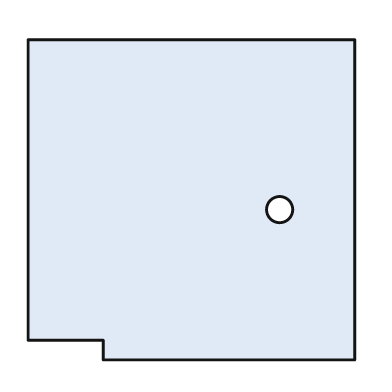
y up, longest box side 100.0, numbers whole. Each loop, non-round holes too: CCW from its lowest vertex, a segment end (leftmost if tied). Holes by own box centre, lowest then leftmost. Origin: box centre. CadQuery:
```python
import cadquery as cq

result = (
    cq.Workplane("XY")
    .moveTo(-27.0, -49.0)
    .lineTo(50.0, -49.0)
    .lineTo(50.0, 49.0)
    .lineTo(-50.0, 49.0)
    .lineTo(-50.0, -43.0)
    .lineTo(-27.0, -43.0)
    .close()
    .moveTo(27.0, -3.0)
    .circle(4.0)
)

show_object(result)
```